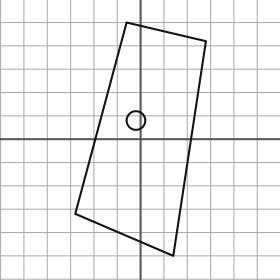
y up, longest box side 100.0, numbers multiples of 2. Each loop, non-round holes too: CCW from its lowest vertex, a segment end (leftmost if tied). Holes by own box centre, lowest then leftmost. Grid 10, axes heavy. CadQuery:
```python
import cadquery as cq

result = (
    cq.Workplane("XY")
    .moveTo(14.0, -50.0)
    .lineTo(28.0, 42.0)
    .lineTo(-6.0, 50.0)
    .lineTo(-28.0, -32.0)
    .close()
    .moveTo(-2.0, 8.0)
    .circle(4.0)
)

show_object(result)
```